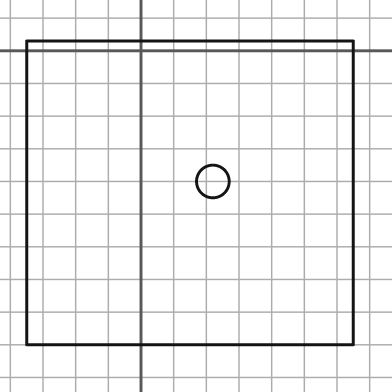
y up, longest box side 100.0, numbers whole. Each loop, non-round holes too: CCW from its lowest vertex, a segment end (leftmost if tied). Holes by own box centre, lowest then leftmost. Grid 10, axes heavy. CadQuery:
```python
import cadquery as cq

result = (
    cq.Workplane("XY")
    .moveTo(-35.0, -90.0)
    .lineTo(65.0, -90.0)
    .lineTo(65.0, 3.0)
    .lineTo(-35.0, 3.0)
    .close()
    .moveTo(22.0, -40.0)
    .circle(5.0)
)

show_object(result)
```